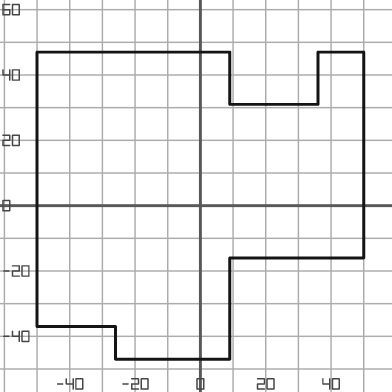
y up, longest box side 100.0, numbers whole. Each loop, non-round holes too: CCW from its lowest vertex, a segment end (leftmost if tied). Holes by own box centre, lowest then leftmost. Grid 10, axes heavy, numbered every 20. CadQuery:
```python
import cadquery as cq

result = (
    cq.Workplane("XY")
    .moveTo(-26.0, -47.0)
    .lineTo(9.0, -47.0)
    .lineTo(9.0, -16.0)
    .lineTo(50.0, -16.0)
    .lineTo(50.0, 47.0)
    .lineTo(36.0, 47.0)
    .lineTo(36.0, 31.0)
    .lineTo(9.0, 31.0)
    .lineTo(9.0, 47.0)
    .lineTo(-50.0, 47.0)
    .lineTo(-50.0, -37.0)
    .lineTo(-26.0, -37.0)
    .close()
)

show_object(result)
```